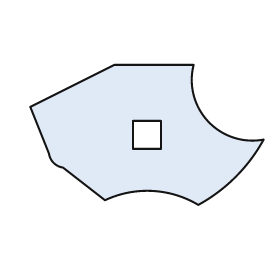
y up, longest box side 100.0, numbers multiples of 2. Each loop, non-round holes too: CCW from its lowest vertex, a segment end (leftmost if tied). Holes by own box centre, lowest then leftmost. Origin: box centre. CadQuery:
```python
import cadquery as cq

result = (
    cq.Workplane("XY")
    .moveTo(22.0, -30.0)
    .threePointArc((38.0, -18.0), (50.0, -2.0))
    .threePointArc((26.0, 6.0), (20.0, 30.0))
    .lineTo(-14.0, 30.0)
    .lineTo(-50.0, 12.0)
    .lineTo(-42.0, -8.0)
    .threePointArc((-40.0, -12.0), (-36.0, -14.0))
    .lineTo(-18.0, -28.0)
    .threePointArc((2.0, -24.0), (22.0, -30.0))
    .close()
    .moveTo(-6.0, -6.0)
    .lineTo(6.0, -6.0)
    .lineTo(6.0, 6.0)
    .lineTo(-6.0, 6.0)
    .close()
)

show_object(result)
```